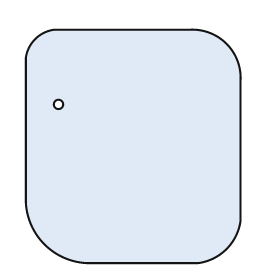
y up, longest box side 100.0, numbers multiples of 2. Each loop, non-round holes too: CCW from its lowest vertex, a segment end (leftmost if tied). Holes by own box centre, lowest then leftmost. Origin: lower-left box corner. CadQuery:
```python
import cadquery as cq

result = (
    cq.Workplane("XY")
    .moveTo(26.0, 0.0)
    .lineTo(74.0, 0.0)
    .threePointArc((86.0, 6.0), (92.0, 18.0))
    .lineTo(92.0, 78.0)
    .threePointArc((86.0, 94.0), (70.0, 100.0))
    .lineTo(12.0, 100.0)
    .threePointArc((4.0, 96.0), (0.0, 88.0))
    .lineTo(0.0, 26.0)
    .threePointArc((8.0, 8.0), (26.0, 0.0))
    .close()
    .moveTo(14.0, 68.0)
    .circle(2.0)
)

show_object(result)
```